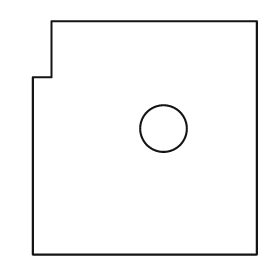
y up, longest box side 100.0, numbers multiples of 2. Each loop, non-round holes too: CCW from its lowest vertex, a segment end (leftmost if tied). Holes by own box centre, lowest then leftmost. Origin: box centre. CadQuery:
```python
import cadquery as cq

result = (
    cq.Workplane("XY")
    .moveTo(-48.0, -50.0)
    .lineTo(48.0, -50.0)
    .lineTo(48.0, 50.0)
    .lineTo(-40.0, 50.0)
    .lineTo(-40.0, 26.0)
    .lineTo(-48.0, 26.0)
    .close()
    .moveTo(8.0, 4.0)
    .circle(10.0)
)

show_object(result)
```